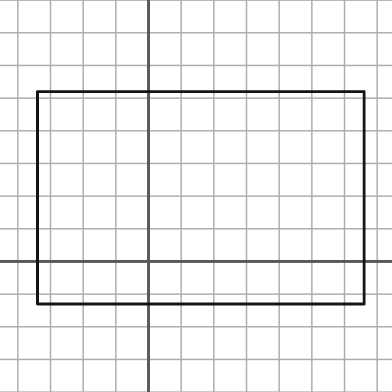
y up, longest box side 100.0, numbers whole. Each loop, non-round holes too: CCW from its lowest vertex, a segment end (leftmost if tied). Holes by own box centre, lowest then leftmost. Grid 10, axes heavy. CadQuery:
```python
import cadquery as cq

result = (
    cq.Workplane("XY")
    .moveTo(-34.0, -13.0)
    .lineTo(66.0, -13.0)
    .lineTo(66.0, 52.0)
    .lineTo(-34.0, 52.0)
    .close()
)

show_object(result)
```